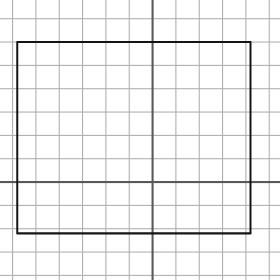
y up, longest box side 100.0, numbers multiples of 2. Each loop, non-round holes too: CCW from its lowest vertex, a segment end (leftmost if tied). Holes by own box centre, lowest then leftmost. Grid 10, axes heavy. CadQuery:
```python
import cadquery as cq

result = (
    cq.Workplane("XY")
    .moveTo(-58.0, -22.0)
    .lineTo(42.0, -22.0)
    .lineTo(42.0, 60.0)
    .lineTo(-58.0, 60.0)
    .close()
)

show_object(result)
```